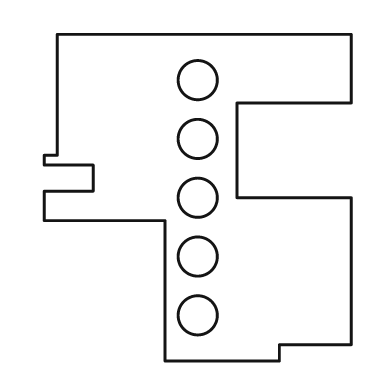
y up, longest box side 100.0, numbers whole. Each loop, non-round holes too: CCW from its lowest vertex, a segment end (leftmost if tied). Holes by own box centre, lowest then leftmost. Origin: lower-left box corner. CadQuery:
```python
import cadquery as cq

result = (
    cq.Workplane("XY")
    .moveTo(37.0, 0.0)
    .lineTo(72.0, 0.0)
    .lineTo(72.0, 5.0)
    .lineTo(94.0, 5.0)
    .lineTo(94.0, 50.0)
    .lineTo(59.0, 50.0)
    .lineTo(59.0, 79.0)
    .lineTo(94.0, 79.0)
    .lineTo(94.0, 100.0)
    .lineTo(4.0, 100.0)
    .lineTo(4.0, 63.0)
    .lineTo(0.0, 63.0)
    .lineTo(0.0, 60.0)
    .lineTo(15.0, 60.0)
    .lineTo(15.0, 52.0)
    .lineTo(0.0, 52.0)
    .lineTo(0.0, 43.0)
    .lineTo(37.0, 43.0)
    .close()
    .moveTo(47.0, 14.0)
    .circle(6.0)
    .moveTo(47.0, 32.0)
    .circle(6.0)
    .moveTo(47.0, 50.0)
    .circle(6.0)
    .moveTo(47.0, 68.0)
    .circle(6.0)
    .moveTo(47.0, 86.0)
    .circle(6.0)
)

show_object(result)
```